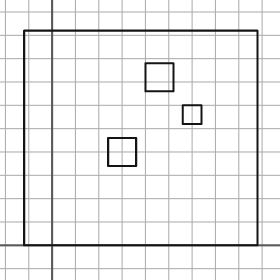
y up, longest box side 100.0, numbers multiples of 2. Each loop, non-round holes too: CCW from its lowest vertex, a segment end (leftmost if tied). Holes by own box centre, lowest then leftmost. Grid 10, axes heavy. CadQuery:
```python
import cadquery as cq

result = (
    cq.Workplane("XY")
    .moveTo(-12.0, 0.0)
    .lineTo(88.0, 0.0)
    .lineTo(88.0, 92.0)
    .lineTo(-12.0, 92.0)
    .close()
    .moveTo(24.0, 34.0)
    .lineTo(36.0, 34.0)
    .lineTo(36.0, 46.0)
    .lineTo(24.0, 46.0)
    .close()
    .moveTo(56.0, 52.0)
    .lineTo(64.0, 52.0)
    .lineTo(64.0, 60.0)
    .lineTo(56.0, 60.0)
    .close()
    .moveTo(40.0, 66.0)
    .lineTo(52.0, 66.0)
    .lineTo(52.0, 78.0)
    .lineTo(40.0, 78.0)
    .close()
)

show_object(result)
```